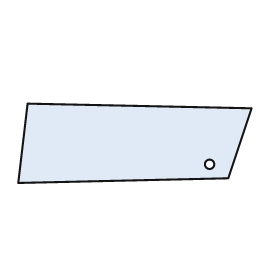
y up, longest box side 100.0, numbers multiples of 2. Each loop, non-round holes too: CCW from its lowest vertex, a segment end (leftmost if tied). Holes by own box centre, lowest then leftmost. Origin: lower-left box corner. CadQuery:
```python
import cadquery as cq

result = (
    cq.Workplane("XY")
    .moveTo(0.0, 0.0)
    .lineTo(90.0, 2.0)
    .lineTo(100.0, 32.0)
    .lineTo(4.0, 34.0)
    .close()
    .moveTo(82.0, 8.0)
    .circle(2.0)
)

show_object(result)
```